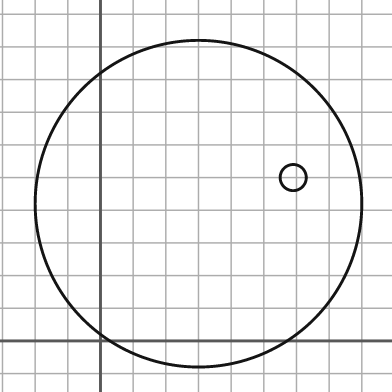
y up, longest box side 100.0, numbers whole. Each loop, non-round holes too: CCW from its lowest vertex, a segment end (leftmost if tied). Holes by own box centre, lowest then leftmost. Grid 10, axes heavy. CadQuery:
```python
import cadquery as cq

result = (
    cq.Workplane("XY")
    .moveTo(30.0, 42.0)
    .circle(50.0)
    .moveTo(59.0, 50.0)
    .circle(4.0)
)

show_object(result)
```